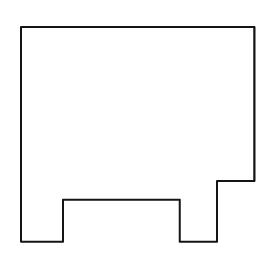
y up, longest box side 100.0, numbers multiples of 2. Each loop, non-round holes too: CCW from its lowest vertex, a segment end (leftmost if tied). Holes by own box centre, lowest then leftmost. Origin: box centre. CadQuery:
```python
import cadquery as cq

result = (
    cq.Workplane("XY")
    .moveTo(-50.0, -46.0)
    .lineTo(-32.0, -46.0)
    .lineTo(-32.0, -28.0)
    .lineTo(18.0, -28.0)
    .lineTo(18.0, -46.0)
    .lineTo(34.0, -46.0)
    .lineTo(34.0, -20.0)
    .lineTo(50.0, -20.0)
    .lineTo(50.0, 46.0)
    .lineTo(-50.0, 46.0)
    .close()
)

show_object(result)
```